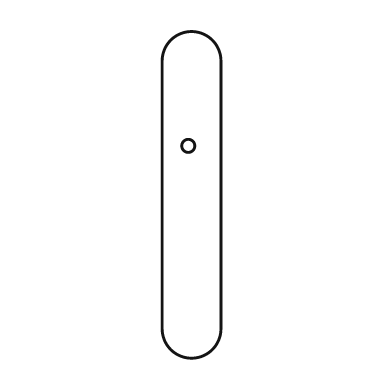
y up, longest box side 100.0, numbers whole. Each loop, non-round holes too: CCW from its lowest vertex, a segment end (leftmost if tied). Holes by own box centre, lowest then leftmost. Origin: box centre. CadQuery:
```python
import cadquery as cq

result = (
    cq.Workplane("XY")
    .moveTo(-9.0, -41.0)
    .threePointArc((0.0, -50.0), (9.0, -41.0))
    .lineTo(9.0, 41.0)
    .threePointArc((0.0, 50.0), (-9.0, 41.0))
    .close()
    .moveTo(-1.0, 15.0)
    .circle(2.0)
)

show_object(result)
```